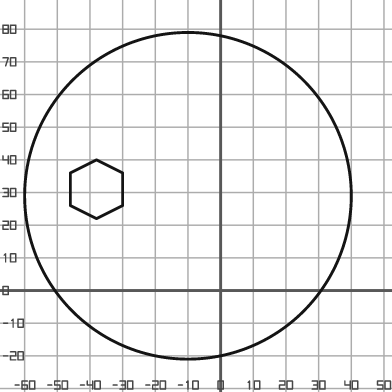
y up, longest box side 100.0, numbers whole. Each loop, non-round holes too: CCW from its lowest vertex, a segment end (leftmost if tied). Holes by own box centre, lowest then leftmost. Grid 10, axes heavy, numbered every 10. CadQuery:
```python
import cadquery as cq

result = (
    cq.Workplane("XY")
    .moveTo(-10.0, 29.0)
    .circle(50.0)
    .moveTo(-38.0, 22.0)
    .lineTo(-30.0, 26.0)
    .lineTo(-30.0, 36.0)
    .lineTo(-38.0, 40.0)
    .lineTo(-46.0, 36.0)
    .lineTo(-46.0, 26.0)
    .close()
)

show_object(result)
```